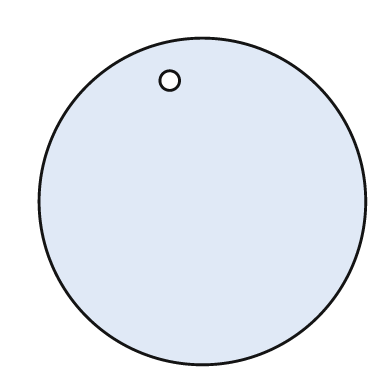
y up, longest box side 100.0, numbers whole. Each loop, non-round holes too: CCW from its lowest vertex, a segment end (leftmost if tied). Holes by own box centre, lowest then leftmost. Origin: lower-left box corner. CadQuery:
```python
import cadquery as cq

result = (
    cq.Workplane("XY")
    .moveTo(50.0, 50.0)
    .circle(50.0)
    .moveTo(40.0, 87.0)
    .circle(3.0)
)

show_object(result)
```